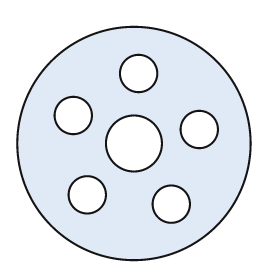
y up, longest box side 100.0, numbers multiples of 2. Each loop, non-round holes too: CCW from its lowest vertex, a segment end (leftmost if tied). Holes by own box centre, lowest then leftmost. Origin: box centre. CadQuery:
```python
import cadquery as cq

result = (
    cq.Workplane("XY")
    .moveTo(0.0, 0.0)
    .circle(50.0)
    .moveTo(16.0, -26.0)
    .circle(8.0)
    .moveTo(-20.0, -22.0)
    .circle(8.0)
    .moveTo(0.0, 0.0)
    .circle(12.0)
    .moveTo(28.0, 6.0)
    .circle(8.0)
    .moveTo(-26.0, 12.0)
    .circle(8.0)
    .moveTo(2.0, 30.0)
    .circle(8.0)
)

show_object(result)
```